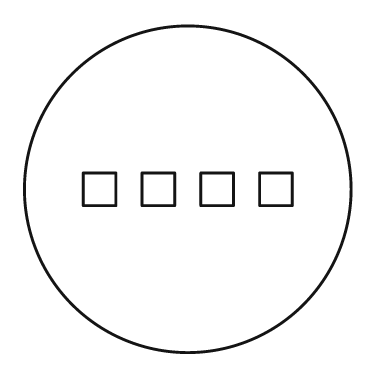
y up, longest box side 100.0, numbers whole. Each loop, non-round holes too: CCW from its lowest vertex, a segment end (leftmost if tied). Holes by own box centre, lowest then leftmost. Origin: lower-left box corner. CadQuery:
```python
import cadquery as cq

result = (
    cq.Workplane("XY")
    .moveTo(50.0, 50.0)
    .circle(50.0)
    .moveTo(18.0, 45.0)
    .lineTo(28.0, 45.0)
    .lineTo(28.0, 55.0)
    .lineTo(18.0, 55.0)
    .close()
    .moveTo(36.0, 45.0)
    .lineTo(46.0, 45.0)
    .lineTo(46.0, 55.0)
    .lineTo(36.0, 55.0)
    .close()
    .moveTo(54.0, 45.0)
    .lineTo(64.0, 45.0)
    .lineTo(64.0, 55.0)
    .lineTo(54.0, 55.0)
    .close()
    .moveTo(72.0, 45.0)
    .lineTo(82.0, 45.0)
    .lineTo(82.0, 55.0)
    .lineTo(72.0, 55.0)
    .close()
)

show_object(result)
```